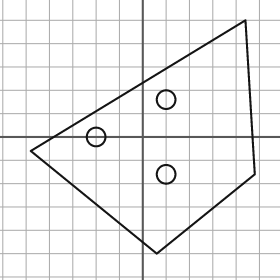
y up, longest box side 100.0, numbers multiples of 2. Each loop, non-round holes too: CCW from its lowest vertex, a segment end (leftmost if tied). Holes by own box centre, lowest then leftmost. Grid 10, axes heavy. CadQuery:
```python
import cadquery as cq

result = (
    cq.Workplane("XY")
    .moveTo(6.0, -50.0)
    .lineTo(48.0, -16.0)
    .lineTo(44.0, 50.0)
    .lineTo(-48.0, -6.0)
    .close()
    .moveTo(10.0, -16.0)
    .circle(4.0)
    .moveTo(-20.0, 0.0)
    .circle(4.0)
    .moveTo(10.0, 16.0)
    .circle(4.0)
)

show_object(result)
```